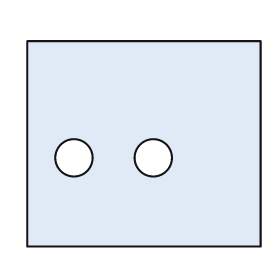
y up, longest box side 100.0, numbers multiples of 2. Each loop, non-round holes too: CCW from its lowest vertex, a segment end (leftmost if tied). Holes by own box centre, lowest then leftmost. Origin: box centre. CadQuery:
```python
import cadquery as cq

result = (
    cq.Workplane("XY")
    .moveTo(-50.0, -44.0)
    .lineTo(50.0, -44.0)
    .lineTo(50.0, 44.0)
    .lineTo(-50.0, 44.0)
    .close()
    .moveTo(-30.0, -6.0)
    .circle(8.0)
    .moveTo(4.0, -6.0)
    .circle(8.0)
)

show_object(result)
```